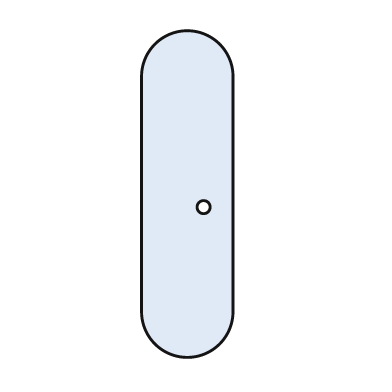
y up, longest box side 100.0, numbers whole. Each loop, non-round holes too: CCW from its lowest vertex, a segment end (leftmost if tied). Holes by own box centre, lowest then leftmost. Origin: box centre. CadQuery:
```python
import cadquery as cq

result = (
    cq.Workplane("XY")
    .moveTo(-14.0, -36.0)
    .threePointArc((0.0, -50.0), (14.0, -36.0))
    .lineTo(14.0, 36.0)
    .threePointArc((0.0, 50.0), (-14.0, 36.0))
    .close()
    .moveTo(5.0, -4.0)
    .circle(2.0)
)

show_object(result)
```